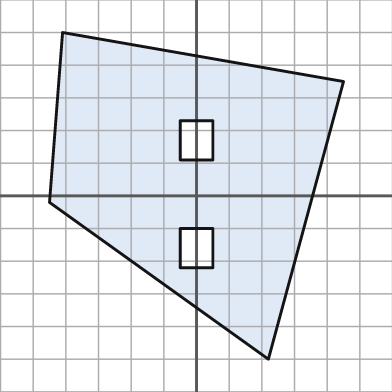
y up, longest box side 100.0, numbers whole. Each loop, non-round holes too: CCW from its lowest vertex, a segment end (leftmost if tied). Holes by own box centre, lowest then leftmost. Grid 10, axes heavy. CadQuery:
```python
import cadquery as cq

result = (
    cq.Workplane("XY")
    .moveTo(22.0, -50.0)
    .lineTo(45.0, 35.0)
    .lineTo(-41.0, 50.0)
    .lineTo(-45.0, -2.0)
    .close()
    .moveTo(-5.0, -22.0)
    .lineTo(5.0, -22.0)
    .lineTo(5.0, -10.0)
    .lineTo(-5.0, -10.0)
    .close()
    .moveTo(-5.0, 11.0)
    .lineTo(5.0, 11.0)
    .lineTo(5.0, 23.0)
    .lineTo(-5.0, 23.0)
    .close()
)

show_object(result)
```